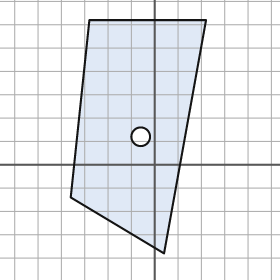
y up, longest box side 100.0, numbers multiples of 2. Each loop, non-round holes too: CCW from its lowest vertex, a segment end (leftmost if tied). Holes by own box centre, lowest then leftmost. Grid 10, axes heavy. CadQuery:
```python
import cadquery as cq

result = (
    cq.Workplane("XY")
    .moveTo(4.0, -38.0)
    .lineTo(22.0, 62.0)
    .lineTo(-28.0, 62.0)
    .lineTo(-36.0, -14.0)
    .close()
    .moveTo(-6.0, 12.0)
    .circle(4.0)
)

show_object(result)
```